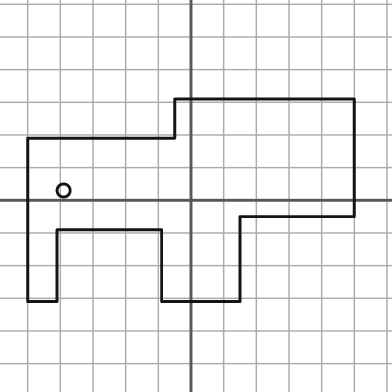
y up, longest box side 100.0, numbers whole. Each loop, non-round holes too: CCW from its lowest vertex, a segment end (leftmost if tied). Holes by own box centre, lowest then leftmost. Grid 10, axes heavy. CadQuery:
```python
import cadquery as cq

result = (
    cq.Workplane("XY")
    .moveTo(-50.0, -31.0)
    .lineTo(-41.0, -31.0)
    .lineTo(-41.0, -9.0)
    .lineTo(-9.0, -9.0)
    .lineTo(-9.0, -31.0)
    .lineTo(15.0, -31.0)
    .lineTo(15.0, -5.0)
    .lineTo(50.0, -5.0)
    .lineTo(50.0, 31.0)
    .lineTo(-5.0, 31.0)
    .lineTo(-5.0, 19.0)
    .lineTo(-50.0, 19.0)
    .close()
    .moveTo(-39.0, 3.0)
    .circle(2.0)
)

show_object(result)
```